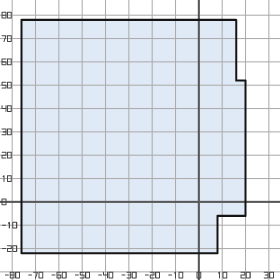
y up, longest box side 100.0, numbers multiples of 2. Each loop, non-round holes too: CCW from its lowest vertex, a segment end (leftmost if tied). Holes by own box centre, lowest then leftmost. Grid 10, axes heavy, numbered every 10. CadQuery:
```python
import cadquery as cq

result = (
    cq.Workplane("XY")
    .moveTo(-76.0, -22.0)
    .lineTo(8.0, -22.0)
    .lineTo(8.0, -6.0)
    .lineTo(20.0, -6.0)
    .lineTo(20.0, 52.0)
    .lineTo(16.0, 52.0)
    .lineTo(16.0, 78.0)
    .lineTo(-76.0, 78.0)
    .close()
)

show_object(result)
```